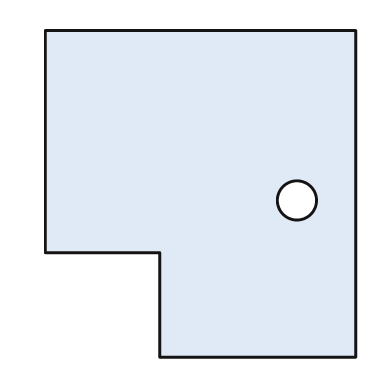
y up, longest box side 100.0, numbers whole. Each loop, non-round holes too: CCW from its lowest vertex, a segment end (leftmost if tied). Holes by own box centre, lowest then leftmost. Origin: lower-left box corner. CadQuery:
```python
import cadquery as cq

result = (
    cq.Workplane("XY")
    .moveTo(35.0, 0.0)
    .lineTo(95.0, 0.0)
    .lineTo(95.0, 100.0)
    .lineTo(0.0, 100.0)
    .lineTo(0.0, 32.0)
    .lineTo(35.0, 32.0)
    .close()
    .moveTo(77.0, 48.0)
    .circle(6.0)
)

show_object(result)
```